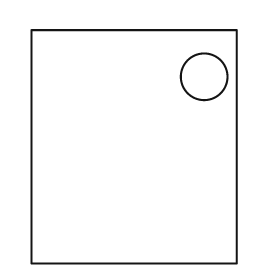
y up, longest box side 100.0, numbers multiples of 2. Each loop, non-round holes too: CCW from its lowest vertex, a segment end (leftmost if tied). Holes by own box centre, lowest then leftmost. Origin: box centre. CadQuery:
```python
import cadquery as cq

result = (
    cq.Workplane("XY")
    .moveTo(-44.0, -50.0)
    .lineTo(44.0, -50.0)
    .lineTo(44.0, 50.0)
    .lineTo(-44.0, 50.0)
    .close()
    .moveTo(30.0, 30.0)
    .circle(10.0)
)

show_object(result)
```